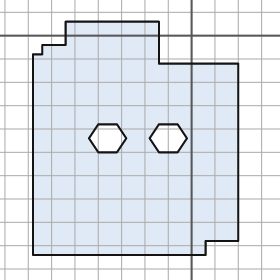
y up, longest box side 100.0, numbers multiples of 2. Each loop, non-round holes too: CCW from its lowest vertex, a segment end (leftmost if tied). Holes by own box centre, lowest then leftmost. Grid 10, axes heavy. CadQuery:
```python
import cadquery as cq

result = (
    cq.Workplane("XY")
    .moveTo(-68.0, -94.0)
    .lineTo(6.0, -94.0)
    .lineTo(6.0, -88.0)
    .lineTo(20.0, -88.0)
    .lineTo(20.0, -12.0)
    .lineTo(-14.0, -12.0)
    .lineTo(-14.0, 6.0)
    .lineTo(-54.0, 6.0)
    .lineTo(-54.0, -4.0)
    .lineTo(-64.0, -4.0)
    .lineTo(-64.0, -8.0)
    .lineTo(-68.0, -8.0)
    .close()
    .moveTo(-40.0, -50.0)
    .lineTo(-32.0, -50.0)
    .lineTo(-28.0, -44.0)
    .lineTo(-32.0, -38.0)
    .lineTo(-40.0, -38.0)
    .lineTo(-44.0, -44.0)
    .close()
    .moveTo(-14.0, -50.0)
    .lineTo(-6.0, -50.0)
    .lineTo(-2.0, -44.0)
    .lineTo(-6.0, -38.0)
    .lineTo(-14.0, -38.0)
    .lineTo(-18.0, -44.0)
    .close()
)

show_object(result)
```